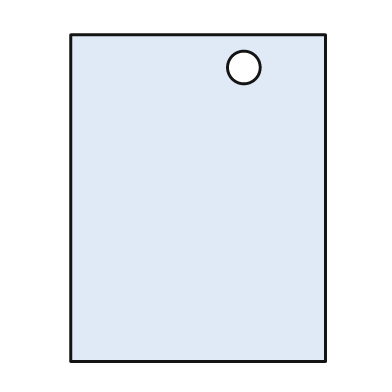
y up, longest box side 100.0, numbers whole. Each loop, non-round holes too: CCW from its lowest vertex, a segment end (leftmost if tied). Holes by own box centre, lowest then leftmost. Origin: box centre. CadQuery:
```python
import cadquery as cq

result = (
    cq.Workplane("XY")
    .moveTo(-39.0, -50.0)
    .lineTo(39.0, -50.0)
    .lineTo(39.0, 50.0)
    .lineTo(-39.0, 50.0)
    .close()
    .moveTo(14.0, 40.0)
    .circle(5.0)
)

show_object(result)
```